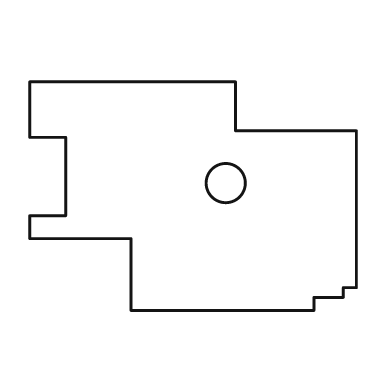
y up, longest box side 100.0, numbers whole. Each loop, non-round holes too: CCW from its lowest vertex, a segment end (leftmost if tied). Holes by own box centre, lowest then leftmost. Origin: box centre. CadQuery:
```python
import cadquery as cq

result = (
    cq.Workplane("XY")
    .moveTo(-19.0, -35.0)
    .lineTo(37.0, -35.0)
    .lineTo(37.0, -31.0)
    .lineTo(46.0, -31.0)
    .lineTo(46.0, -28.0)
    .lineTo(50.0, -28.0)
    .lineTo(50.0, 20.0)
    .lineTo(13.0, 20.0)
    .lineTo(13.0, 35.0)
    .lineTo(-50.0, 35.0)
    .lineTo(-50.0, 18.0)
    .lineTo(-39.0, 18.0)
    .lineTo(-39.0, -6.0)
    .lineTo(-50.0, -6.0)
    .lineTo(-50.0, -13.0)
    .lineTo(-19.0, -13.0)
    .close()
    .moveTo(10.0, 4.0)
    .circle(6.0)
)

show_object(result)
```